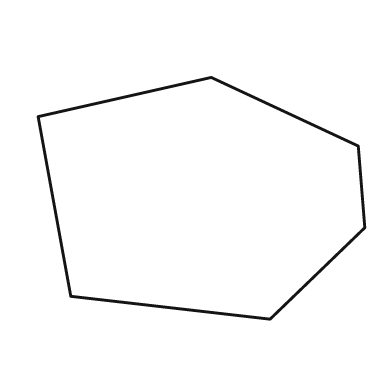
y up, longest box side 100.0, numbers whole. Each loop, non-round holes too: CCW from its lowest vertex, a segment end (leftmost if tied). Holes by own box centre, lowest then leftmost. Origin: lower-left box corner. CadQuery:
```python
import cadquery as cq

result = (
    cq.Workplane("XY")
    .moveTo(71.0, 0.0)
    .lineTo(100.0, 28.0)
    .lineTo(98.0, 53.0)
    .lineTo(53.0, 74.0)
    .lineTo(0.0, 62.0)
    .lineTo(10.0, 7.0)
    .close()
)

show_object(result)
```